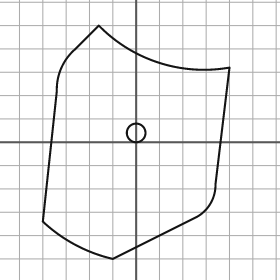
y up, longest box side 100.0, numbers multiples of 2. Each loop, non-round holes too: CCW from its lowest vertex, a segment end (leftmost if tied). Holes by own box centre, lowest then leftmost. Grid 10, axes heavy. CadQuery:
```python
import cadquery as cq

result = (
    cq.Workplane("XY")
    .moveTo(-10.0, -50.0)
    .lineTo(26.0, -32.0)
    .threePointArc((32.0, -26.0), (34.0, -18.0))
    .lineTo(40.0, 32.0)
    .threePointArc((10.0, 34.0), (-16.0, 50.0))
    .lineTo(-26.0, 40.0)
    .threePointArc((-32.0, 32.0), (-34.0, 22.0))
    .lineTo(-40.0, -34.0)
    .threePointArc((-26.0, -44.0), (-10.0, -50.0))
    .close()
    .moveTo(0.0, 4.0)
    .circle(4.0)
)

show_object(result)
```